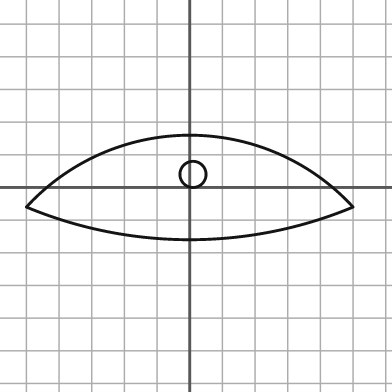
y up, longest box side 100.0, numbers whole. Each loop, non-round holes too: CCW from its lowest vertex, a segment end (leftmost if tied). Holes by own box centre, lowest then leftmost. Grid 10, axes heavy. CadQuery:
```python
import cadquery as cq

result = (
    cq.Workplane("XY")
    .moveTo(-50.0, -6.0)
    .threePointArc((0.0, -16.0), (50.0, -6.0))
    .threePointArc((0.0, 16.0), (-50.0, -6.0))
    .close()
    .moveTo(1.0, 4.0)
    .circle(4.0)
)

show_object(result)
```